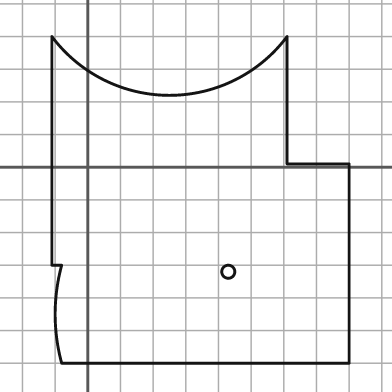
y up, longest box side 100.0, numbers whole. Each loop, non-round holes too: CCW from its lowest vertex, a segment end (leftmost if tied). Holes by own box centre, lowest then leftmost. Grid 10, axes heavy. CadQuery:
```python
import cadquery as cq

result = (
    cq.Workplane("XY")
    .moveTo(-8.0, -60.0)
    .lineTo(80.0, -60.0)
    .lineTo(80.0, 1.0)
    .lineTo(61.0, 1.0)
    .lineTo(61.0, 40.0)
    .threePointArc((25.0, 22.0), (-11.0, 40.0))
    .lineTo(-11.0, -30.0)
    .lineTo(-8.0, -30.0)
    .threePointArc((-10.0, -45.0), (-8.0, -60.0))
    .close()
    .moveTo(43.0, -32.0)
    .circle(2.0)
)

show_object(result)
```